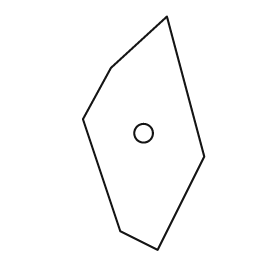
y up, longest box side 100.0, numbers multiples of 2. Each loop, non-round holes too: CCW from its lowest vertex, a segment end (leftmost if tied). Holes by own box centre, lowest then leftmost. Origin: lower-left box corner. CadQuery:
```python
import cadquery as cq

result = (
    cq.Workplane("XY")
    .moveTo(32.0, 0.0)
    .lineTo(52.0, 40.0)
    .lineTo(36.0, 100.0)
    .lineTo(12.0, 78.0)
    .lineTo(0.0, 56.0)
    .lineTo(16.0, 8.0)
    .close()
    .moveTo(26.0, 50.0)
    .circle(4.0)
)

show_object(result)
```